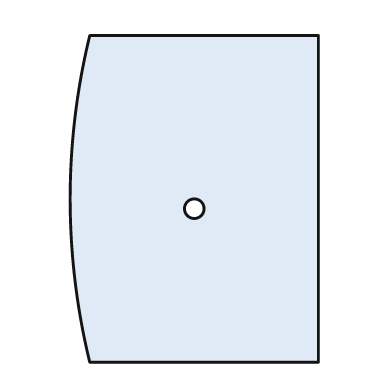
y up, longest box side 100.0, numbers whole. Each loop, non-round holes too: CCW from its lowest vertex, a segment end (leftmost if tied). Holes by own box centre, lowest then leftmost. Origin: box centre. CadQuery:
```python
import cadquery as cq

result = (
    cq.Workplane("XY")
    .moveTo(-32.0, -50.0)
    .lineTo(38.0, -50.0)
    .lineTo(38.0, 50.0)
    .lineTo(-32.0, 50.0)
    .threePointArc((-38.0, 0.0), (-32.0, -50.0))
    .close()
    .moveTo(0.0, -3.0)
    .circle(3.0)
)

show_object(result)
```